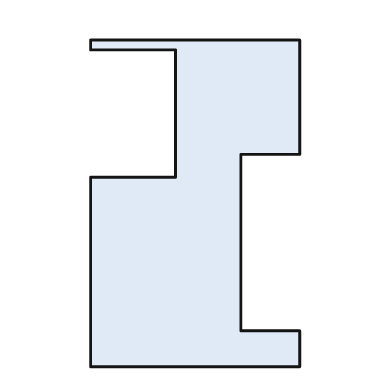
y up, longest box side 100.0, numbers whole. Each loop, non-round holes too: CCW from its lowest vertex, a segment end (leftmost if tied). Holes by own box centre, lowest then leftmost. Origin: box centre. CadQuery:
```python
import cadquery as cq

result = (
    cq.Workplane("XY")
    .moveTo(-32.0, -50.0)
    .lineTo(32.0, -50.0)
    .lineTo(32.0, -39.0)
    .lineTo(14.0, -39.0)
    .lineTo(14.0, 15.0)
    .lineTo(32.0, 15.0)
    .lineTo(32.0, 50.0)
    .lineTo(-32.0, 50.0)
    .lineTo(-32.0, 47.0)
    .lineTo(-6.0, 47.0)
    .lineTo(-6.0, 8.0)
    .lineTo(-32.0, 8.0)
    .close()
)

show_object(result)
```